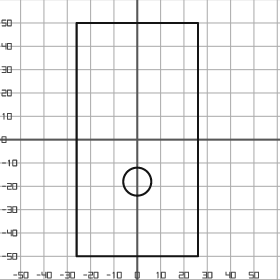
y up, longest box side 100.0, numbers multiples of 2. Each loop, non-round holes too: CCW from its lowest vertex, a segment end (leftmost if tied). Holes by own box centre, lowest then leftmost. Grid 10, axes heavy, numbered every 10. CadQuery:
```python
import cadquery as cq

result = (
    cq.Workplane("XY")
    .moveTo(-26.0, -50.0)
    .lineTo(26.0, -50.0)
    .lineTo(26.0, 50.0)
    .lineTo(-26.0, 50.0)
    .close()
    .moveTo(0.0, -18.0)
    .circle(6.0)
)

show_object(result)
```